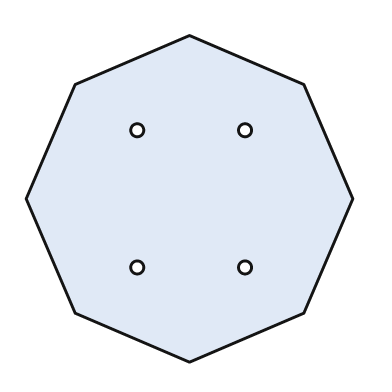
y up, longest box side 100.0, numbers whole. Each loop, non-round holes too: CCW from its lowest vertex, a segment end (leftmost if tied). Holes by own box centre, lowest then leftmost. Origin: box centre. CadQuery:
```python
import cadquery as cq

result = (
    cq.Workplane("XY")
    .moveTo(0.0, -50.0)
    .lineTo(35.0, -35.0)
    .lineTo(50.0, 0.0)
    .lineTo(35.0, 35.0)
    .lineTo(0.0, 50.0)
    .lineTo(-35.0, 35.0)
    .lineTo(-50.0, 0.0)
    .lineTo(-35.0, -35.0)
    .close()
    .moveTo(-16.0, -21.0)
    .circle(2.0)
    .moveTo(17.0, -21.0)
    .circle(2.0)
    .moveTo(-16.0, 21.0)
    .circle(2.0)
    .moveTo(17.0, 21.0)
    .circle(2.0)
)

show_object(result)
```